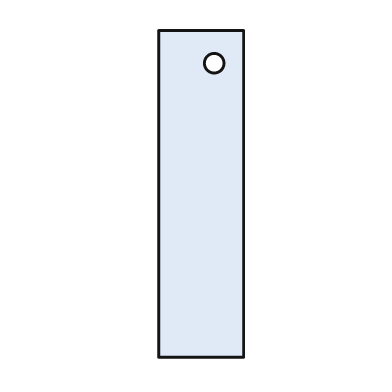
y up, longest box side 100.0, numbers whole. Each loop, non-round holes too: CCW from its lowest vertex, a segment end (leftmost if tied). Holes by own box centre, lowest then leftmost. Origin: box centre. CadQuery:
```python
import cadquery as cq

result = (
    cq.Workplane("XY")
    .moveTo(-13.0, -50.0)
    .lineTo(13.0, -50.0)
    .lineTo(13.0, 50.0)
    .lineTo(-13.0, 50.0)
    .close()
    .moveTo(4.0, 40.0)
    .circle(3.0)
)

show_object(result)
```